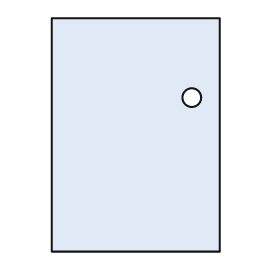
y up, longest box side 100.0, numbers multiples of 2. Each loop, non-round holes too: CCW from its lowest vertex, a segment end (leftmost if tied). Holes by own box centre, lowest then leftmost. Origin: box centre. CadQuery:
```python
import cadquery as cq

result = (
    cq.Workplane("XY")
    .moveTo(-36.0, -50.0)
    .lineTo(36.0, -50.0)
    .lineTo(36.0, 50.0)
    .lineTo(-36.0, 50.0)
    .close()
    .moveTo(24.0, 16.0)
    .circle(4.0)
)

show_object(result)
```